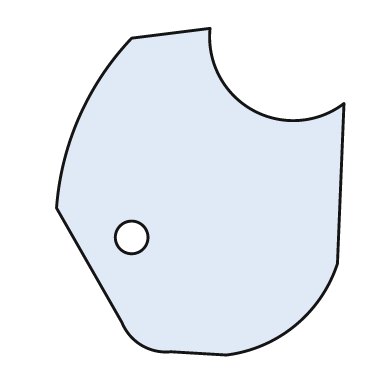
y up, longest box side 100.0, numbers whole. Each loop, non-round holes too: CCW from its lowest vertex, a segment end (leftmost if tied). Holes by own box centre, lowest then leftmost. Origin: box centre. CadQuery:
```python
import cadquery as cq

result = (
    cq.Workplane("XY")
    .moveTo(8.0, -50.0)
    .threePointArc((29.0, -41.0), (42.0, -22.0))
    .lineTo(44.0, 27.0)
    .threePointArc((16.0, 25.0), (3.0, 50.0))
    .lineTo(-21.0, 47.0)
    .threePointArc((-37.0, 23.0), (-44.0, -5.0))
    .lineTo(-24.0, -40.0)
    .threePointArc((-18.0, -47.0), (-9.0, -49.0))
    .close()
    .moveTo(-21.0, -14.0)
    .circle(5.0)
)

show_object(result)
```